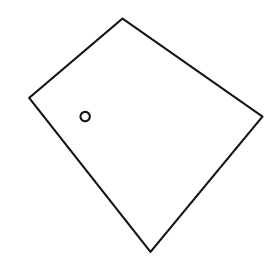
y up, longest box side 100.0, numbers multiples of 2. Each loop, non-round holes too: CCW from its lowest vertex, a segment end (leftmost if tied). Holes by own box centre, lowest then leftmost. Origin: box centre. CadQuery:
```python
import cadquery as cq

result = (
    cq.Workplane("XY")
    .moveTo(2.0, -50.0)
    .lineTo(50.0, 8.0)
    .lineTo(-10.0, 50.0)
    .lineTo(-50.0, 16.0)
    .close()
    .moveTo(-26.0, 8.0)
    .circle(2.0)
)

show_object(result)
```